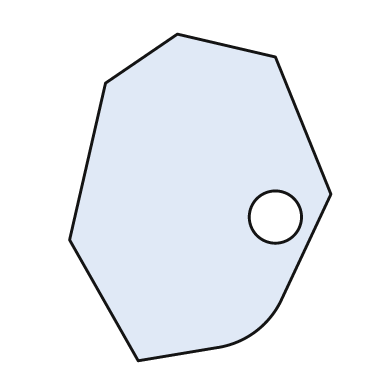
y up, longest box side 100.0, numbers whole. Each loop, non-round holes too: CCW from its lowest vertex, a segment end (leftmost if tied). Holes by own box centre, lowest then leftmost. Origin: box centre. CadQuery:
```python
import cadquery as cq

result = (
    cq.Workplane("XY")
    .moveTo(-19.0, -50.0)
    .lineTo(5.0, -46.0)
    .threePointArc((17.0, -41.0), (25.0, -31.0))
    .lineTo(40.0, 1.0)
    .lineTo(23.0, 43.0)
    .lineTo(-7.0, 50.0)
    .lineTo(-29.0, 35.0)
    .lineTo(-40.0, -13.0)
    .close()
    .moveTo(23.0, -6.0)
    .circle(8.0)
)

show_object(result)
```